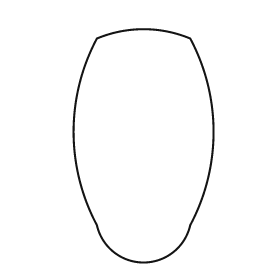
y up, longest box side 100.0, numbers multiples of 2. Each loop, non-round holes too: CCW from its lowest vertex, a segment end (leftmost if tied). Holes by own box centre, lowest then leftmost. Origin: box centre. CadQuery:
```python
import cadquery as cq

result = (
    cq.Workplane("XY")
    .moveTo(-20.0, -34.0)
    .threePointArc((0.0, -50.0), (20.0, -34.0))
    .threePointArc((30.0, 6.0), (20.0, 46.0))
    .threePointArc((0.0, 50.0), (-20.0, 46.0))
    .threePointArc((-30.0, 6.0), (-20.0, -34.0))
    .close()
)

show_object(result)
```